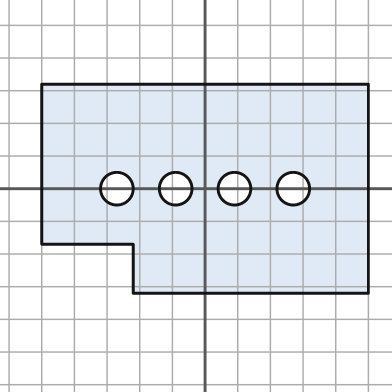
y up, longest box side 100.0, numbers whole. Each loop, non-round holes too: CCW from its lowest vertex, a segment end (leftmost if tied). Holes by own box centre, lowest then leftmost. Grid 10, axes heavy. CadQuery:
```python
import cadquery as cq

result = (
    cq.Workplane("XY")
    .moveTo(-22.0, -32.0)
    .lineTo(50.0, -32.0)
    .lineTo(50.0, 32.0)
    .lineTo(-50.0, 32.0)
    .lineTo(-50.0, -17.0)
    .lineTo(-22.0, -17.0)
    .close()
    .moveTo(-27.0, 0.0)
    .circle(5.0)
    .moveTo(-9.0, 0.0)
    .circle(5.0)
    .moveTo(9.0, 0.0)
    .circle(5.0)
    .moveTo(27.0, 0.0)
    .circle(5.0)
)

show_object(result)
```